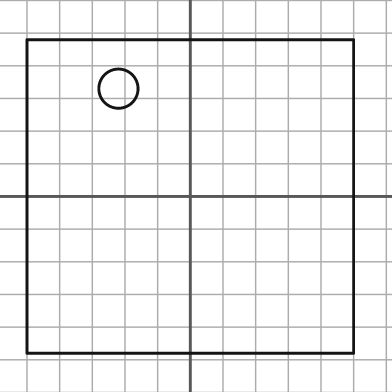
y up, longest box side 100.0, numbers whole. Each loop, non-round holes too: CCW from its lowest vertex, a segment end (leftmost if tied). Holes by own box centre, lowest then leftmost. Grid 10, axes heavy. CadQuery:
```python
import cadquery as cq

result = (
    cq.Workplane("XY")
    .moveTo(-50.0, -48.0)
    .lineTo(50.0, -48.0)
    .lineTo(50.0, 48.0)
    .lineTo(-50.0, 48.0)
    .close()
    .moveTo(-22.0, 33.0)
    .circle(6.0)
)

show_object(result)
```